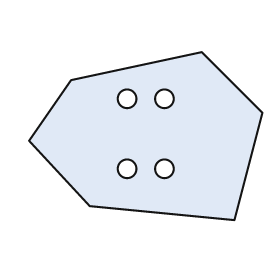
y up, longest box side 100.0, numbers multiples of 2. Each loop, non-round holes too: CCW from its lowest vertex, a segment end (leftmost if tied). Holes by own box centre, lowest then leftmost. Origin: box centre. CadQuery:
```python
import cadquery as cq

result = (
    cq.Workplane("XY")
    .moveTo(38.0, -36.0)
    .lineTo(50.0, 10.0)
    .lineTo(24.0, 36.0)
    .lineTo(-32.0, 24.0)
    .lineTo(-50.0, -2.0)
    .lineTo(-24.0, -30.0)
    .close()
    .moveTo(-8.0, -14.0)
    .circle(4.0)
    .moveTo(8.0, -14.0)
    .circle(4.0)
    .moveTo(-8.0, 16.0)
    .circle(4.0)
    .moveTo(8.0, 16.0)
    .circle(4.0)
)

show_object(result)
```